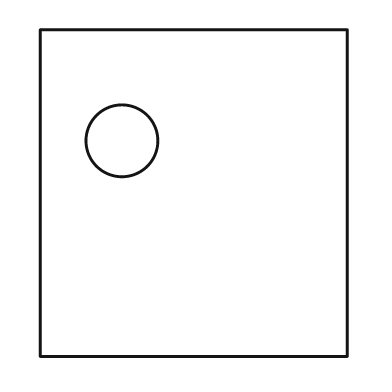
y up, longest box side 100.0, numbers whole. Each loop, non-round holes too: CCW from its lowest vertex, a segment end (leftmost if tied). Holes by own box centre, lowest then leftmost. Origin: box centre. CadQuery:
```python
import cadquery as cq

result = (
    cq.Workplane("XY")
    .moveTo(-47.0, -50.0)
    .lineTo(47.0, -50.0)
    .lineTo(47.0, 50.0)
    .lineTo(-47.0, 50.0)
    .close()
    .moveTo(-22.0, 16.0)
    .circle(11.0)
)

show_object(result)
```